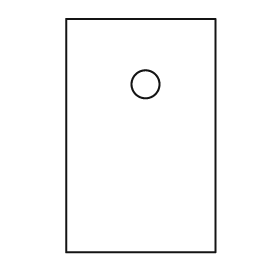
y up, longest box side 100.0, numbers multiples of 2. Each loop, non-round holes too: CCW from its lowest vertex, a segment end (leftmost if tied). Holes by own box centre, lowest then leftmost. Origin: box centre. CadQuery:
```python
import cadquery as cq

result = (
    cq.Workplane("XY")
    .moveTo(-32.0, -50.0)
    .lineTo(32.0, -50.0)
    .lineTo(32.0, 50.0)
    .lineTo(-32.0, 50.0)
    .close()
    .moveTo(2.0, 22.0)
    .circle(6.0)
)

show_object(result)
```